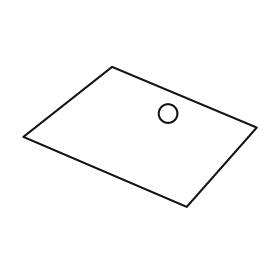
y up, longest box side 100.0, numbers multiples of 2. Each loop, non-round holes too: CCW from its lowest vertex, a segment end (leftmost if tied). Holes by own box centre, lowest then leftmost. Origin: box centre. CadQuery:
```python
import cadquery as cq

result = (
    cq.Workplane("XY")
    .moveTo(20.0, -30.0)
    .lineTo(50.0, 4.0)
    .lineTo(-12.0, 30.0)
    .lineTo(-50.0, 0.0)
    .close()
    .moveTo(12.0, 10.0)
    .circle(4.0)
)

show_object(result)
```